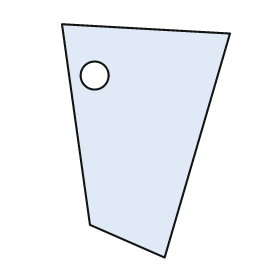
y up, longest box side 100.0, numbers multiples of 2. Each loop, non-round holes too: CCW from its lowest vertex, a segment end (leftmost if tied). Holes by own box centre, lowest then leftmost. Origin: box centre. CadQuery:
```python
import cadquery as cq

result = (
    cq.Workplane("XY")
    .moveTo(8.0, -50.0)
    .lineTo(36.0, 46.0)
    .lineTo(-36.0, 50.0)
    .lineTo(-24.0, -36.0)
    .close()
    .moveTo(-22.0, 28.0)
    .circle(6.0)
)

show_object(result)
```